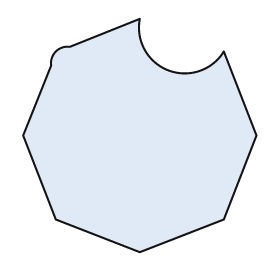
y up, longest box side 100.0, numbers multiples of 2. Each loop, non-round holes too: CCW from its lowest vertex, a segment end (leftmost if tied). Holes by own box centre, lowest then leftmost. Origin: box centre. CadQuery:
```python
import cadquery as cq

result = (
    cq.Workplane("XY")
    .moveTo(0.0, -50.0)
    .lineTo(36.0, -36.0)
    .lineTo(50.0, 0.0)
    .lineTo(36.0, 36.0)
    .threePointArc((12.0, 28.0), (0.0, 50.0))
    .lineTo(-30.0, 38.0)
    .threePointArc((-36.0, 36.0), (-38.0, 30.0))
    .lineTo(-50.0, 0.0)
    .lineTo(-36.0, -36.0)
    .close()
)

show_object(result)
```